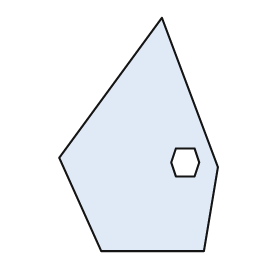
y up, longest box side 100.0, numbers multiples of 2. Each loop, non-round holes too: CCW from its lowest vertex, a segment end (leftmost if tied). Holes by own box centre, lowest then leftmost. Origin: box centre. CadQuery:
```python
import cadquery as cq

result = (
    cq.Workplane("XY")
    .moveTo(-16.0, -50.0)
    .lineTo(28.0, -50.0)
    .lineTo(34.0, -14.0)
    .lineTo(10.0, 50.0)
    .lineTo(-34.0, -10.0)
    .close()
    .moveTo(16.0, -18.0)
    .lineTo(24.0, -18.0)
    .lineTo(26.0, -12.0)
    .lineTo(24.0, -6.0)
    .lineTo(16.0, -6.0)
    .lineTo(14.0, -12.0)
    .close()
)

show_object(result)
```